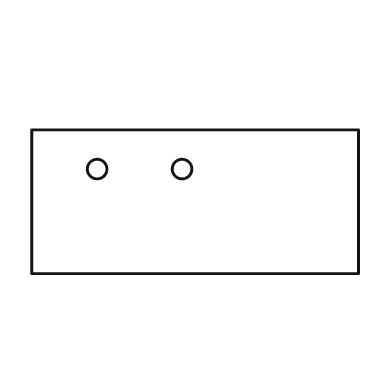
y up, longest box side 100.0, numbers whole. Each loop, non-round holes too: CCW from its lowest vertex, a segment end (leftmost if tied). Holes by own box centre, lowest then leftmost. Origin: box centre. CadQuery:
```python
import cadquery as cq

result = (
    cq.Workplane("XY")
    .moveTo(-50.0, -22.0)
    .lineTo(50.0, -22.0)
    .lineTo(50.0, 22.0)
    .lineTo(-50.0, 22.0)
    .close()
    .moveTo(-30.0, 10.0)
    .circle(3.0)
    .moveTo(-4.0, 10.0)
    .circle(3.0)
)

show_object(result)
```